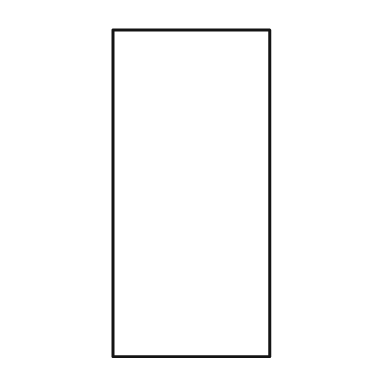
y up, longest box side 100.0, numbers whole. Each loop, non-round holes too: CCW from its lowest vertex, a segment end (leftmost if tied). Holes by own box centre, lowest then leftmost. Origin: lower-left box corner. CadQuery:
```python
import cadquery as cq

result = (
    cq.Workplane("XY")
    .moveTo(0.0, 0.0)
    .lineTo(48.0, 0.0)
    .lineTo(48.0, 100.0)
    .lineTo(0.0, 100.0)
    .close()
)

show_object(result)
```